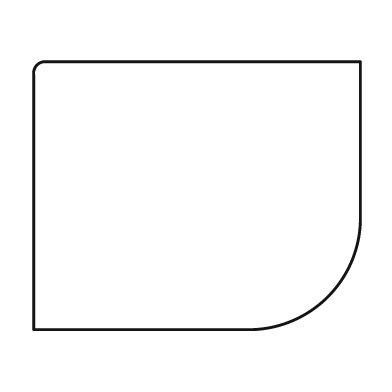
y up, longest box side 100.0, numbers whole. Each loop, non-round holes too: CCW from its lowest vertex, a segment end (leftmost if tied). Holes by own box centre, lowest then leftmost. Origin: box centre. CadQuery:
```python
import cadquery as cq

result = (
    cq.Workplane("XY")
    .moveTo(-50.0, -41.0)
    .lineTo(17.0, -41.0)
    .threePointArc((40.0, -31.0), (50.0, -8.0))
    .lineTo(50.0, 41.0)
    .lineTo(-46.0, 41.0)
    .threePointArc((-49.0, 40.0), (-50.0, 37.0))
    .close()
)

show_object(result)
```